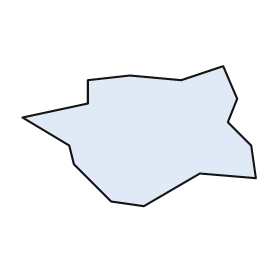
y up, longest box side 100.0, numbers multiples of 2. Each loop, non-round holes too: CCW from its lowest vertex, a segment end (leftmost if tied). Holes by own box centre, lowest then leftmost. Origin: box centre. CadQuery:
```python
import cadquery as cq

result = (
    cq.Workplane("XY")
    .moveTo(2.0, -30.0)
    .lineTo(26.0, -16.0)
    .lineTo(50.0, -18.0)
    .lineTo(48.0, -4.0)
    .lineTo(38.0, 6.0)
    .lineTo(42.0, 16.0)
    .lineTo(36.0, 30.0)
    .lineTo(18.0, 24.0)
    .lineTo(-4.0, 26.0)
    .lineTo(-22.0, 24.0)
    .lineTo(-22.0, 14.0)
    .lineTo(-50.0, 8.0)
    .lineTo(-30.0, -4.0)
    .lineTo(-28.0, -12.0)
    .lineTo(-12.0, -28.0)
    .close()
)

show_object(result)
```